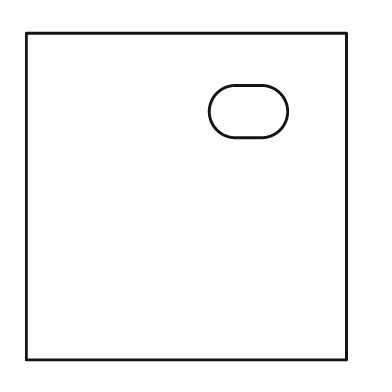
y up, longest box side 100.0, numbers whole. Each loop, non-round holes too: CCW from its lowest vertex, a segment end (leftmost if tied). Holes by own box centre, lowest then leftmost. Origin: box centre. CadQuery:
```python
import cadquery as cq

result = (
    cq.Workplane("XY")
    .moveTo(-49.0, -50.0)
    .lineTo(49.0, -50.0)
    .lineTo(49.0, 50.0)
    .lineTo(-49.0, 50.0)
    .close()
    .moveTo(15.0, 18.0)
    .lineTo(23.0, 18.0)
    .threePointArc((31.0, 26.0), (23.0, 34.0))
    .lineTo(15.0, 34.0)
    .threePointArc((7.0, 26.0), (15.0, 18.0))
    .close()
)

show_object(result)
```